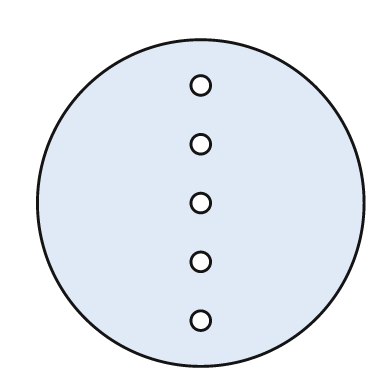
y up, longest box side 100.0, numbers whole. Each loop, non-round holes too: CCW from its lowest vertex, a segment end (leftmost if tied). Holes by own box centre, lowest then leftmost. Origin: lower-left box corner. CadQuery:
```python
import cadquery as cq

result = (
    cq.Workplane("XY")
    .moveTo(50.0, 50.0)
    .circle(50.0)
    .moveTo(50.0, 14.0)
    .circle(3.0)
    .moveTo(50.0, 32.0)
    .circle(3.0)
    .moveTo(50.0, 50.0)
    .circle(3.0)
    .moveTo(50.0, 68.0)
    .circle(3.0)
    .moveTo(50.0, 86.0)
    .circle(3.0)
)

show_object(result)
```